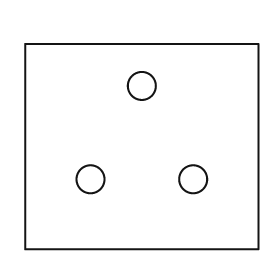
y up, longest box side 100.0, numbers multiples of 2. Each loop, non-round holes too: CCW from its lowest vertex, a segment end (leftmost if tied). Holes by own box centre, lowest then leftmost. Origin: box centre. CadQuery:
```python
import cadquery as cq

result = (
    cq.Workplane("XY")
    .moveTo(-50.0, -44.0)
    .lineTo(50.0, -44.0)
    .lineTo(50.0, 44.0)
    .lineTo(-50.0, 44.0)
    .close()
    .moveTo(-22.0, -14.0)
    .circle(6.0)
    .moveTo(22.0, -14.0)
    .circle(6.0)
    .moveTo(0.0, 26.0)
    .circle(6.0)
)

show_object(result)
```